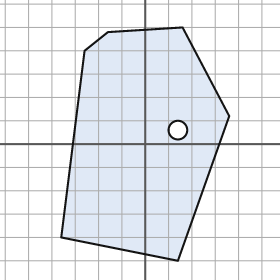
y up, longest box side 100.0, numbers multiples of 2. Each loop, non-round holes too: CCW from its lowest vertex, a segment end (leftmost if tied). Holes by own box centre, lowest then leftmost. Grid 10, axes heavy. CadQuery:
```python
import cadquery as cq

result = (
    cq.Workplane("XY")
    .moveTo(14.0, -50.0)
    .lineTo(36.0, 12.0)
    .lineTo(16.0, 50.0)
    .lineTo(-16.0, 48.0)
    .lineTo(-26.0, 40.0)
    .lineTo(-36.0, -40.0)
    .close()
    .moveTo(14.0, 6.0)
    .circle(4.0)
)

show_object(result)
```